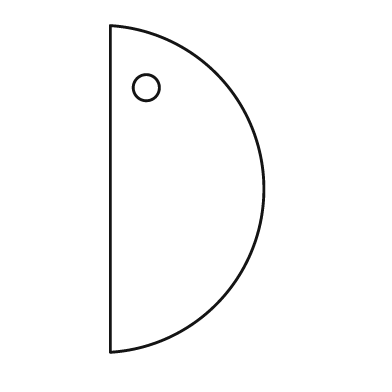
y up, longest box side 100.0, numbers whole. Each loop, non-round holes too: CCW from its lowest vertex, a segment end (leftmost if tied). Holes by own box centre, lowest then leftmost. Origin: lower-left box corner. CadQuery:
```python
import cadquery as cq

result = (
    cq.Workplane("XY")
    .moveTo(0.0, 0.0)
    .threePointArc((47.0, 50.0), (0.0, 100.0))
    .close()
    .moveTo(11.0, 81.0)
    .circle(4.0)
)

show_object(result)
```